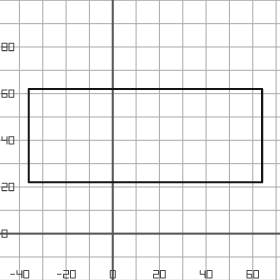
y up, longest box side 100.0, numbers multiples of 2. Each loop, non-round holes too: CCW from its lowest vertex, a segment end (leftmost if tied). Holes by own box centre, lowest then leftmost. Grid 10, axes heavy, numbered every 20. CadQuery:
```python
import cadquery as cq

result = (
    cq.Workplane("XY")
    .moveTo(-36.0, 22.0)
    .lineTo(64.0, 22.0)
    .lineTo(64.0, 62.0)
    .lineTo(-36.0, 62.0)
    .close()
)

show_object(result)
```